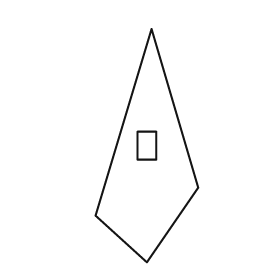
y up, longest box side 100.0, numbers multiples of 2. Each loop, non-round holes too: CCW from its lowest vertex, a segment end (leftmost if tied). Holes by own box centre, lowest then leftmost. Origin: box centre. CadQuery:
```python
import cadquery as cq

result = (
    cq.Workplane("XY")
    .moveTo(0.0, -50.0)
    .lineTo(22.0, -18.0)
    .lineTo(2.0, 50.0)
    .lineTo(-22.0, -30.0)
    .close()
    .moveTo(-4.0, -6.0)
    .lineTo(4.0, -6.0)
    .lineTo(4.0, 6.0)
    .lineTo(-4.0, 6.0)
    .close()
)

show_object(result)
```